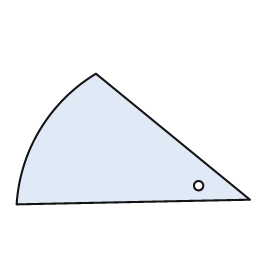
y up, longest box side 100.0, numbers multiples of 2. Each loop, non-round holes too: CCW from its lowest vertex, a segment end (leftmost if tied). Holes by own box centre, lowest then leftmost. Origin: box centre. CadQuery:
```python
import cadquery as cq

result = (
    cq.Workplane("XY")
    .moveTo(-50.0, -28.0)
    .lineTo(50.0, -26.0)
    .lineTo(-16.0, 28.0)
    .threePointArc((-40.0, 4.0), (-50.0, -28.0))
    .close()
    .moveTo(28.0, -20.0)
    .circle(2.0)
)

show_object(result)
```